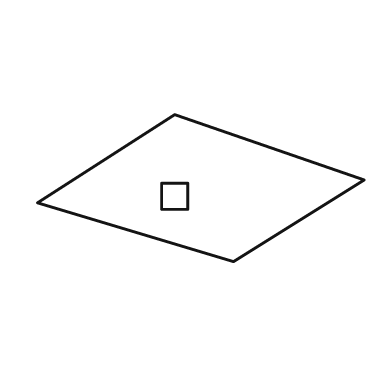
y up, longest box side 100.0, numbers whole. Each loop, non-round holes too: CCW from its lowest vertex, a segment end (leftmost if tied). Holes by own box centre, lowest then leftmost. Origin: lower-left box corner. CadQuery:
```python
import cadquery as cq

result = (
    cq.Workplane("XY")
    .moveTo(60.0, 0.0)
    .lineTo(100.0, 25.0)
    .lineTo(42.0, 45.0)
    .lineTo(0.0, 18.0)
    .close()
    .moveTo(38.0, 16.0)
    .lineTo(46.0, 16.0)
    .lineTo(46.0, 24.0)
    .lineTo(38.0, 24.0)
    .close()
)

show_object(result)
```